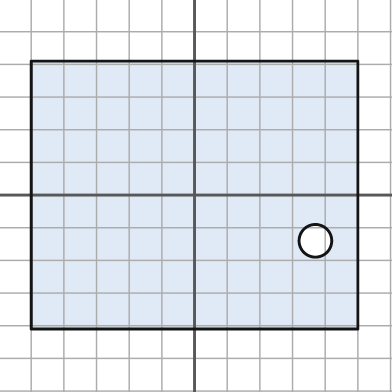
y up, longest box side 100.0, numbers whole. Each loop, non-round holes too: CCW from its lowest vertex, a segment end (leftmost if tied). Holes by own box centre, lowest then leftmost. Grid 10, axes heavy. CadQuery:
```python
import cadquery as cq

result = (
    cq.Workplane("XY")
    .moveTo(-50.0, -41.0)
    .lineTo(50.0, -41.0)
    .lineTo(50.0, 41.0)
    .lineTo(-50.0, 41.0)
    .close()
    .moveTo(37.0, -14.0)
    .circle(5.0)
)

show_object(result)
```